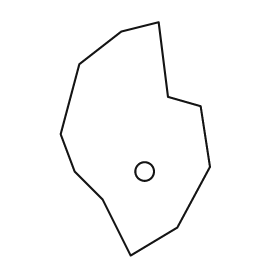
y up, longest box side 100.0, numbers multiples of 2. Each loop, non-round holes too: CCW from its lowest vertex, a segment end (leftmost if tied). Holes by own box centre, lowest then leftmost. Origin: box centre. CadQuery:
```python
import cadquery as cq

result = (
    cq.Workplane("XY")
    .moveTo(-2.0, -50.0)
    .lineTo(18.0, -38.0)
    .lineTo(32.0, -12.0)
    .lineTo(28.0, 14.0)
    .lineTo(14.0, 18.0)
    .lineTo(10.0, 50.0)
    .lineTo(-6.0, 46.0)
    .lineTo(-24.0, 32.0)
    .lineTo(-32.0, 2.0)
    .lineTo(-26.0, -14.0)
    .lineTo(-14.0, -26.0)
    .close()
    .moveTo(4.0, -14.0)
    .circle(4.0)
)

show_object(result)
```